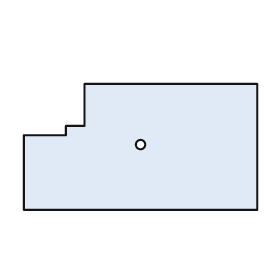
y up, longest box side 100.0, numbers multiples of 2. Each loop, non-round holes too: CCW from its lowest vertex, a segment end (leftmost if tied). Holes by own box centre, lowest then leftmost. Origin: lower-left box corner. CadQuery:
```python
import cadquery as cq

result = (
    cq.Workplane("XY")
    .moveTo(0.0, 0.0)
    .lineTo(100.0, 0.0)
    .lineTo(100.0, 54.0)
    .lineTo(26.0, 54.0)
    .lineTo(26.0, 36.0)
    .lineTo(18.0, 36.0)
    .lineTo(18.0, 32.0)
    .lineTo(0.0, 32.0)
    .close()
    .moveTo(50.0, 28.0)
    .circle(2.0)
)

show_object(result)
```